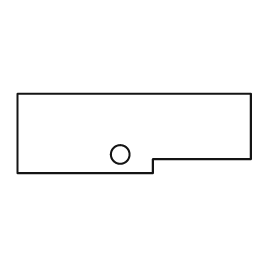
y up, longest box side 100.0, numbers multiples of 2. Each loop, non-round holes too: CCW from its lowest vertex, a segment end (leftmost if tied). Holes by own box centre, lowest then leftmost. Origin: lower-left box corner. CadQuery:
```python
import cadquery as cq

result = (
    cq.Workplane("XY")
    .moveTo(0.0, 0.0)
    .lineTo(58.0, 0.0)
    .lineTo(58.0, 6.0)
    .lineTo(100.0, 6.0)
    .lineTo(100.0, 34.0)
    .lineTo(0.0, 34.0)
    .close()
    .moveTo(44.0, 8.0)
    .circle(4.0)
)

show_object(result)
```